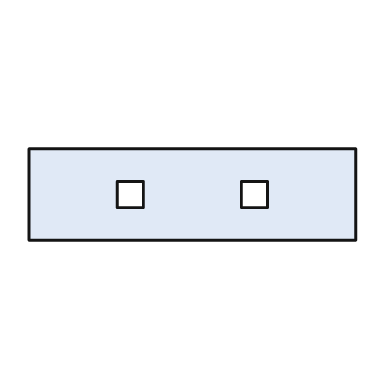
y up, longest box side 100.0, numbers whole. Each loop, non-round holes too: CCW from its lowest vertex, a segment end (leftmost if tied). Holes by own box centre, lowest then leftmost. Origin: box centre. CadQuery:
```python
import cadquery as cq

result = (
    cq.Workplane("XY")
    .moveTo(-50.0, -14.0)
    .lineTo(50.0, -14.0)
    .lineTo(50.0, 14.0)
    .lineTo(-50.0, 14.0)
    .close()
    .moveTo(-23.0, -4.0)
    .lineTo(-15.0, -4.0)
    .lineTo(-15.0, 4.0)
    .lineTo(-23.0, 4.0)
    .close()
    .moveTo(15.0, -4.0)
    .lineTo(23.0, -4.0)
    .lineTo(23.0, 4.0)
    .lineTo(15.0, 4.0)
    .close()
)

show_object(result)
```